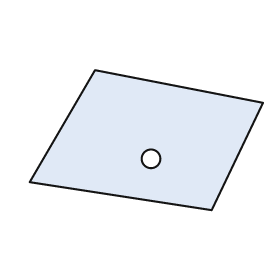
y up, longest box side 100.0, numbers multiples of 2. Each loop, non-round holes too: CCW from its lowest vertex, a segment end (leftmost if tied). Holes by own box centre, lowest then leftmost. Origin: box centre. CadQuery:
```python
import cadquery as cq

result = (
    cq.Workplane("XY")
    .moveTo(28.0, -30.0)
    .lineTo(50.0, 16.0)
    .lineTo(-22.0, 30.0)
    .lineTo(-50.0, -18.0)
    .close()
    .moveTo(2.0, -8.0)
    .circle(4.0)
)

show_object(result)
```